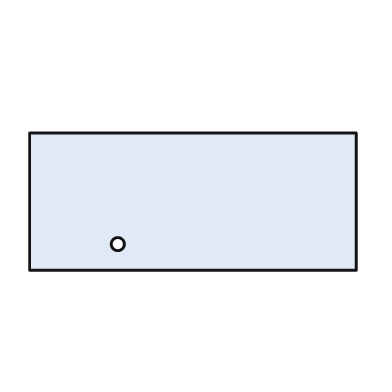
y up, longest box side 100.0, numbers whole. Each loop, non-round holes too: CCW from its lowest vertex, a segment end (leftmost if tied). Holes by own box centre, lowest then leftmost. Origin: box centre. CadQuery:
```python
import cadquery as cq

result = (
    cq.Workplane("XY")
    .moveTo(-50.0, -21.0)
    .lineTo(50.0, -21.0)
    .lineTo(50.0, 21.0)
    .lineTo(-50.0, 21.0)
    .close()
    .moveTo(-23.0, -13.0)
    .circle(2.0)
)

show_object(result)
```